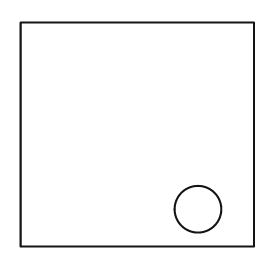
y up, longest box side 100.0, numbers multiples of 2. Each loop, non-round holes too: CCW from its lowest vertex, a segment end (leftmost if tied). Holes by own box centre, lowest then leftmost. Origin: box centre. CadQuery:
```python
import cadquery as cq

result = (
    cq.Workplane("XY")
    .moveTo(-50.0, -48.0)
    .lineTo(50.0, -48.0)
    .lineTo(50.0, 48.0)
    .lineTo(-50.0, 48.0)
    .close()
    .moveTo(26.0, -32.0)
    .circle(10.0)
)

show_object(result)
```